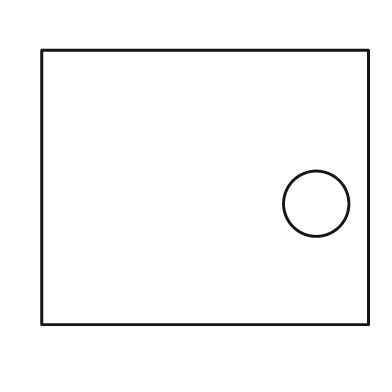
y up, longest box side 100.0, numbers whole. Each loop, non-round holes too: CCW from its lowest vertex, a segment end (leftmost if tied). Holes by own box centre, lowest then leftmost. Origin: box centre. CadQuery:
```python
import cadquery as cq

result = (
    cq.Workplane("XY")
    .moveTo(-50.0, -42.0)
    .lineTo(50.0, -42.0)
    .lineTo(50.0, 42.0)
    .lineTo(-50.0, 42.0)
    .close()
    .moveTo(34.0, -5.0)
    .circle(10.0)
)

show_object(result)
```